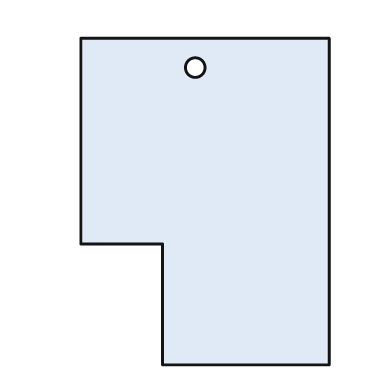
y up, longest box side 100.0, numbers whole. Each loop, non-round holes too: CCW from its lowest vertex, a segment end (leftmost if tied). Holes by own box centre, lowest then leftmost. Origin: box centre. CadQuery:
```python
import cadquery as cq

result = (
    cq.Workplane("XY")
    .moveTo(-13.0, -50.0)
    .lineTo(38.0, -50.0)
    .lineTo(38.0, 50.0)
    .lineTo(-38.0, 50.0)
    .lineTo(-38.0, -13.0)
    .lineTo(-13.0, -13.0)
    .close()
    .moveTo(-3.0, 41.0)
    .circle(3.0)
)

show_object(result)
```